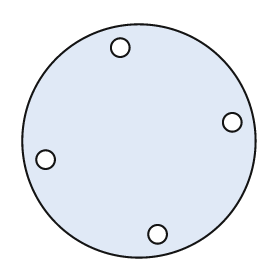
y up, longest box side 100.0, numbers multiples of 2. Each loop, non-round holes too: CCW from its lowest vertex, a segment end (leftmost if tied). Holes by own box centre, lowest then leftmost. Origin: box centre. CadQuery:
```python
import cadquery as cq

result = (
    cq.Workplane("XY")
    .moveTo(0.0, 0.0)
    .circle(50.0)
    .moveTo(8.0, -40.0)
    .circle(4.0)
    .moveTo(-40.0, -8.0)
    .circle(4.0)
    .moveTo(40.0, 8.0)
    .circle(4.0)
    .moveTo(-8.0, 40.0)
    .circle(4.0)
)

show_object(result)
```